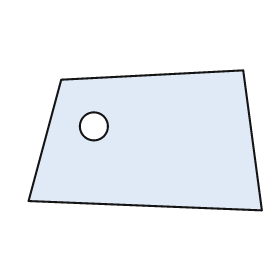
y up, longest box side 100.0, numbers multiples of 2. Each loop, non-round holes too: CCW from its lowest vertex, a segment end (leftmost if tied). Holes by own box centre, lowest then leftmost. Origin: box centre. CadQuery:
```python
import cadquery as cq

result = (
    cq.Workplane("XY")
    .moveTo(50.0, -30.0)
    .lineTo(42.0, 30.0)
    .lineTo(-36.0, 26.0)
    .lineTo(-50.0, -26.0)
    .close()
    .moveTo(-22.0, 6.0)
    .circle(6.0)
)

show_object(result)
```